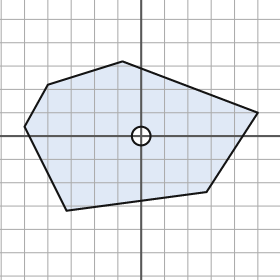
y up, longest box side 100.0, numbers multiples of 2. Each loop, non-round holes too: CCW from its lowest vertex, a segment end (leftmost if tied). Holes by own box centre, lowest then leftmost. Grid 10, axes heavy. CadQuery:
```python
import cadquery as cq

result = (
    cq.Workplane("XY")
    .moveTo(-32.0, -32.0)
    .lineTo(28.0, -24.0)
    .lineTo(50.0, 10.0)
    .lineTo(-8.0, 32.0)
    .lineTo(-40.0, 22.0)
    .lineTo(-50.0, 4.0)
    .close()
    .moveTo(0.0, 0.0)
    .circle(4.0)
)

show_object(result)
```